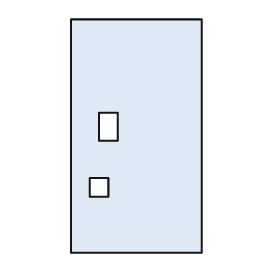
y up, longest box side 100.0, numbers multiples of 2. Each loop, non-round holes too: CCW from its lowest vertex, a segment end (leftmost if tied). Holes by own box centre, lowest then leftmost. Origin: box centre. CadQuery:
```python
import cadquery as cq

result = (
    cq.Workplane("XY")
    .moveTo(-28.0, -50.0)
    .lineTo(28.0, -50.0)
    .lineTo(28.0, 50.0)
    .lineTo(-28.0, 50.0)
    .close()
    .moveTo(-20.0, -26.0)
    .lineTo(-12.0, -26.0)
    .lineTo(-12.0, -18.0)
    .lineTo(-20.0, -18.0)
    .close()
    .moveTo(-16.0, -2.0)
    .lineTo(-8.0, -2.0)
    .lineTo(-8.0, 10.0)
    .lineTo(-16.0, 10.0)
    .close()
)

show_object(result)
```